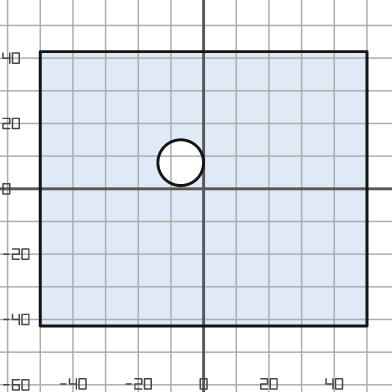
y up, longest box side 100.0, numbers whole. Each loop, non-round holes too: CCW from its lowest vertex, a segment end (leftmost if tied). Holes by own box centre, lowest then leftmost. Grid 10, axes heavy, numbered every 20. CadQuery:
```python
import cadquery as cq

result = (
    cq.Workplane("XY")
    .moveTo(-50.0, -42.0)
    .lineTo(50.0, -42.0)
    .lineTo(50.0, 42.0)
    .lineTo(-50.0, 42.0)
    .close()
    .moveTo(-7.0, 8.0)
    .circle(7.0)
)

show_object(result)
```